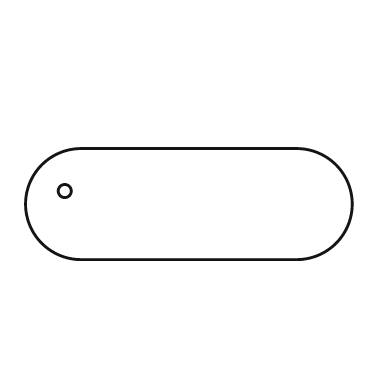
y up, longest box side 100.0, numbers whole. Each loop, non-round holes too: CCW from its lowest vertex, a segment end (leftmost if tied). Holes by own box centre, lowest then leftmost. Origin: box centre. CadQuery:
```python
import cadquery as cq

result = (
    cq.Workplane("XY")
    .moveTo(-33.0, -17.0)
    .lineTo(33.0, -17.0)
    .threePointArc((50.0, 0.0), (33.0, 17.0))
    .lineTo(-33.0, 17.0)
    .threePointArc((-50.0, 0.0), (-33.0, -17.0))
    .close()
    .moveTo(-38.0, 4.0)
    .circle(2.0)
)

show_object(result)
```